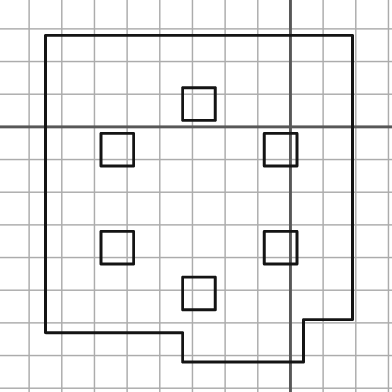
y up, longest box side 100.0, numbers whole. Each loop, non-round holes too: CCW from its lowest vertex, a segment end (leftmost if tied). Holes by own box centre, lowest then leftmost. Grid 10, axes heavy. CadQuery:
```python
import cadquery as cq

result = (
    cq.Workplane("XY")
    .moveTo(-33.0, -72.0)
    .lineTo(4.0, -72.0)
    .lineTo(4.0, -59.0)
    .lineTo(19.0, -59.0)
    .lineTo(19.0, 28.0)
    .lineTo(-75.0, 28.0)
    .lineTo(-75.0, -63.0)
    .lineTo(-33.0, -63.0)
    .close()
    .moveTo(-33.0, -56.0)
    .lineTo(-23.0, -56.0)
    .lineTo(-23.0, -46.0)
    .lineTo(-33.0, -46.0)
    .close()
    .moveTo(-58.0, -42.0)
    .lineTo(-48.0, -42.0)
    .lineTo(-48.0, -32.0)
    .lineTo(-58.0, -32.0)
    .close()
    .moveTo(-8.0, -42.0)
    .lineTo(2.0, -42.0)
    .lineTo(2.0, -32.0)
    .lineTo(-8.0, -32.0)
    .close()
    .moveTo(-58.0, -12.0)
    .lineTo(-48.0, -12.0)
    .lineTo(-48.0, -2.0)
    .lineTo(-58.0, -2.0)
    .close()
    .moveTo(-8.0, -12.0)
    .lineTo(2.0, -12.0)
    .lineTo(2.0, -2.0)
    .lineTo(-8.0, -2.0)
    .close()
    .moveTo(-33.0, 2.0)
    .lineTo(-23.0, 2.0)
    .lineTo(-23.0, 12.0)
    .lineTo(-33.0, 12.0)
    .close()
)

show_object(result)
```